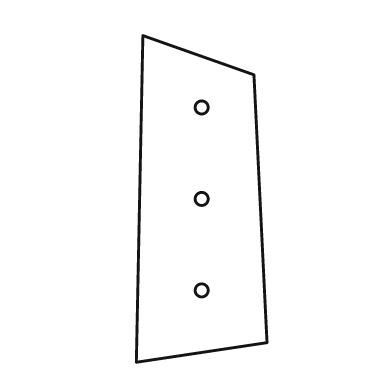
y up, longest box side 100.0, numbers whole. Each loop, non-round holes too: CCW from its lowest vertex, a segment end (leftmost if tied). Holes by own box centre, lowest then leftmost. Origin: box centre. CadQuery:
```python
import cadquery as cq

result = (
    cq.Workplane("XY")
    .moveTo(-20.0, -50.0)
    .lineTo(20.0, -44.0)
    .lineTo(16.0, 38.0)
    .lineTo(-18.0, 50.0)
    .close()
    .moveTo(0.0, -28.0)
    .circle(2.0)
    .moveTo(0.0, 0.0)
    .circle(2.0)
    .moveTo(0.0, 28.0)
    .circle(2.0)
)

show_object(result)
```